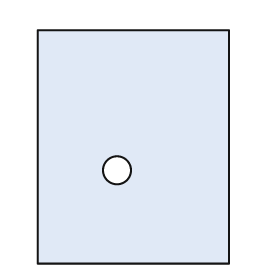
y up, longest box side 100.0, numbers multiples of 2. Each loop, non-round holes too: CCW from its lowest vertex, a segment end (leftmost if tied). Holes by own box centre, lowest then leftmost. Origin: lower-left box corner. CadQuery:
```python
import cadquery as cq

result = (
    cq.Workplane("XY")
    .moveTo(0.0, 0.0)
    .lineTo(82.0, 0.0)
    .lineTo(82.0, 100.0)
    .lineTo(0.0, 100.0)
    .close()
    .moveTo(34.0, 40.0)
    .circle(6.0)
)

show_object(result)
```